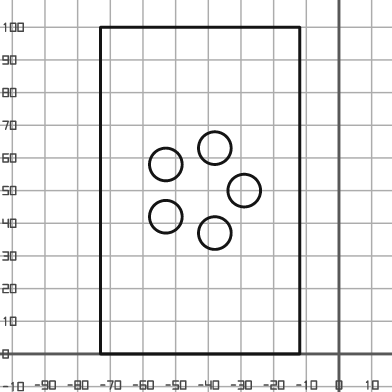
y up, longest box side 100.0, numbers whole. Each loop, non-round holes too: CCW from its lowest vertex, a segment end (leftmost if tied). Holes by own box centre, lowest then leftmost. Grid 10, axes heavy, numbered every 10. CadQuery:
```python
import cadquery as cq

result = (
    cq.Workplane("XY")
    .moveTo(-73.0, 0.0)
    .lineTo(-12.0, 0.0)
    .lineTo(-12.0, 100.0)
    .lineTo(-73.0, 100.0)
    .close()
    .moveTo(-38.0, 37.0)
    .circle(5.0)
    .moveTo(-53.0, 42.0)
    .circle(5.0)
    .moveTo(-29.0, 50.0)
    .circle(5.0)
    .moveTo(-53.0, 58.0)
    .circle(5.0)
    .moveTo(-38.0, 63.0)
    .circle(5.0)
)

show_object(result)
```